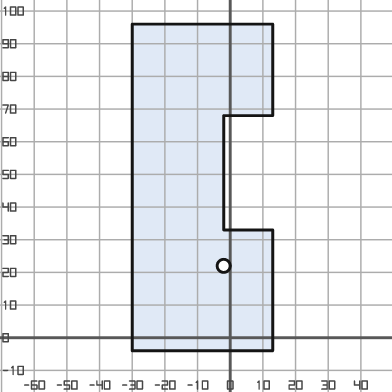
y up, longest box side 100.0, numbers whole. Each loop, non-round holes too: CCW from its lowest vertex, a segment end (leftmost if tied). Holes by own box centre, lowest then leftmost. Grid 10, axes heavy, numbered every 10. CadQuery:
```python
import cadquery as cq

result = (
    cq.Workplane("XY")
    .moveTo(-30.0, -4.0)
    .lineTo(13.0, -4.0)
    .lineTo(13.0, 33.0)
    .lineTo(-2.0, 33.0)
    .lineTo(-2.0, 68.0)
    .lineTo(13.0, 68.0)
    .lineTo(13.0, 96.0)
    .lineTo(-30.0, 96.0)
    .close()
    .moveTo(-2.0, 22.0)
    .circle(2.0)
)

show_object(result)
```